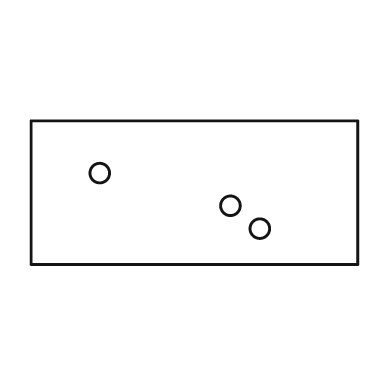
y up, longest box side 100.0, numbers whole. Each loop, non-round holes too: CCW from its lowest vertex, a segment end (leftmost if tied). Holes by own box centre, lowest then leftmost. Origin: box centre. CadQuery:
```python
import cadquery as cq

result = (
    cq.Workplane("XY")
    .moveTo(-50.0, -22.0)
    .lineTo(50.0, -22.0)
    .lineTo(50.0, 22.0)
    .lineTo(-50.0, 22.0)
    .close()
    .moveTo(20.0, -11.0)
    .circle(3.0)
    .moveTo(11.0, -4.0)
    .circle(3.0)
    .moveTo(-29.0, 6.0)
    .circle(3.0)
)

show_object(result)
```